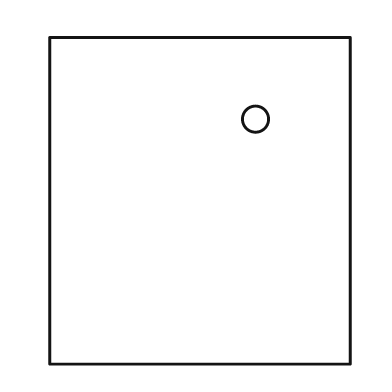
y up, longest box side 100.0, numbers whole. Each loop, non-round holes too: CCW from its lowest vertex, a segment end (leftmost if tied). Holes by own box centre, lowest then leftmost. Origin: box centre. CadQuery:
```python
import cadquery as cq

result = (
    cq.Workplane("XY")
    .moveTo(-46.0, -50.0)
    .lineTo(46.0, -50.0)
    .lineTo(46.0, 50.0)
    .lineTo(-46.0, 50.0)
    .close()
    .moveTo(17.0, 25.0)
    .circle(4.0)
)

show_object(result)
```